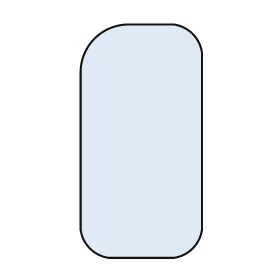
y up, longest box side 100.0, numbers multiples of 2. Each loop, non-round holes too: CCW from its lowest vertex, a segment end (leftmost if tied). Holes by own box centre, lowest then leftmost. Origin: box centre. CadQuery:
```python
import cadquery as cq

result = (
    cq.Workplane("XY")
    .moveTo(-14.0, -50.0)
    .lineTo(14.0, -50.0)
    .threePointArc((22.0, -46.0), (26.0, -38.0))
    .lineTo(26.0, 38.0)
    .threePointArc((22.0, 46.0), (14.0, 50.0))
    .lineTo(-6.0, 50.0)
    .threePointArc((-20.0, 44.0), (-26.0, 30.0))
    .lineTo(-26.0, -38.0)
    .threePointArc((-22.0, -46.0), (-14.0, -50.0))
    .close()
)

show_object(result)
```